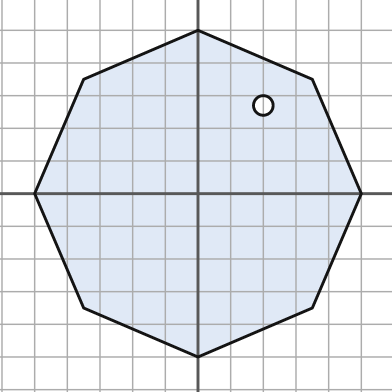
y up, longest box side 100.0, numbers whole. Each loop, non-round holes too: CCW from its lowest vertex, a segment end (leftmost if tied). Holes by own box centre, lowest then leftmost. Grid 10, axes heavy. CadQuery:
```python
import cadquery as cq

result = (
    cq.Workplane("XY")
    .moveTo(0.0, -50.0)
    .lineTo(35.0, -35.0)
    .lineTo(50.0, 0.0)
    .lineTo(35.0, 35.0)
    .lineTo(0.0, 50.0)
    .lineTo(-35.0, 35.0)
    .lineTo(-50.0, 0.0)
    .lineTo(-35.0, -35.0)
    .close()
    .moveTo(20.0, 27.0)
    .circle(3.0)
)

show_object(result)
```